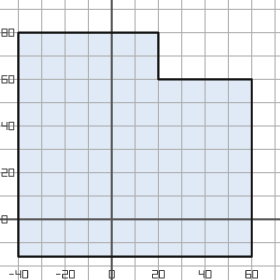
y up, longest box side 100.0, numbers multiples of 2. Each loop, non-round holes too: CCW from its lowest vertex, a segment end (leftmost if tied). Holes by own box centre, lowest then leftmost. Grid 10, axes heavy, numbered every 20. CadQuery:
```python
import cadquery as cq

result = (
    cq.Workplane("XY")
    .moveTo(-40.0, -16.0)
    .lineTo(60.0, -16.0)
    .lineTo(60.0, 60.0)
    .lineTo(20.0, 60.0)
    .lineTo(20.0, 80.0)
    .lineTo(-40.0, 80.0)
    .close()
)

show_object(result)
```